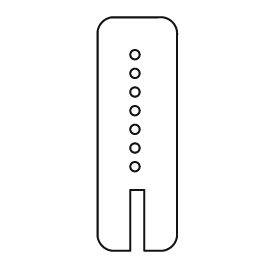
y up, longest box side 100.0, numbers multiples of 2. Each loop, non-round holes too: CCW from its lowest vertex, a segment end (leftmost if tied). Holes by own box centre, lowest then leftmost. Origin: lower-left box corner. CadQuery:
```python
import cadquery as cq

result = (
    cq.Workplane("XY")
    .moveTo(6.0, 0.0)
    .lineTo(14.0, 0.0)
    .lineTo(14.0, 26.0)
    .lineTo(20.0, 26.0)
    .lineTo(20.0, 0.0)
    .lineTo(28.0, 0.0)
    .threePointArc((32.0, 2.0), (34.0, 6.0))
    .lineTo(34.0, 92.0)
    .threePointArc((32.0, 98.0), (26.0, 100.0))
    .lineTo(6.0, 100.0)
    .threePointArc((2.0, 98.0), (0.0, 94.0))
    .lineTo(0.0, 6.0)
    .threePointArc((2.0, 2.0), (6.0, 0.0))
    .close()
    .moveTo(16.0, 36.0)
    .circle(2.0)
    .moveTo(16.0, 44.0)
    .circle(2.0)
    .moveTo(16.0, 52.0)
    .circle(2.0)
    .moveTo(16.0, 60.0)
    .circle(2.0)
    .moveTo(16.0, 68.0)
    .circle(2.0)
    .moveTo(16.0, 76.0)
    .circle(2.0)
    .moveTo(16.0, 84.0)
    .circle(2.0)
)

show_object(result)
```